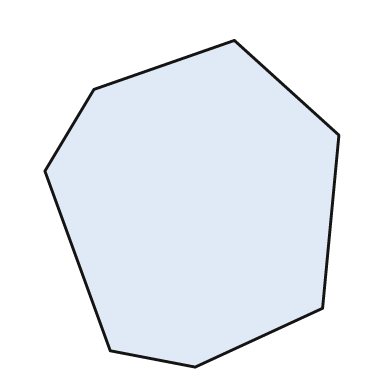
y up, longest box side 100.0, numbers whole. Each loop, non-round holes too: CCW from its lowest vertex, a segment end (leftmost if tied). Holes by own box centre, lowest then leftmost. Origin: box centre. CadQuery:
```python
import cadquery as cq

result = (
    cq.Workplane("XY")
    .moveTo(1.0, -50.0)
    .lineTo(40.0, -32.0)
    .lineTo(45.0, 21.0)
    .lineTo(13.0, 50.0)
    .lineTo(-30.0, 35.0)
    .lineTo(-45.0, 10.0)
    .lineTo(-25.0, -45.0)
    .close()
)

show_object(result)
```